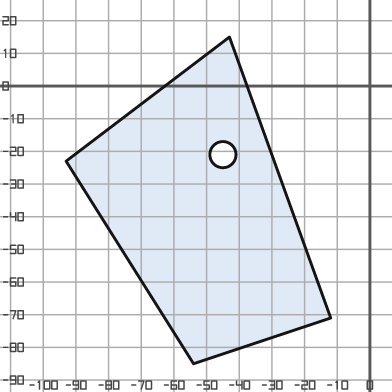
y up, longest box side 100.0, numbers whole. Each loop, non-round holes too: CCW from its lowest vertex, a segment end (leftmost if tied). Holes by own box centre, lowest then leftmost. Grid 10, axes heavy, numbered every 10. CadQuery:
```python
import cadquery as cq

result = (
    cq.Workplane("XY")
    .moveTo(-54.0, -85.0)
    .lineTo(-12.0, -71.0)
    .lineTo(-43.0, 15.0)
    .lineTo(-93.0, -23.0)
    .close()
    .moveTo(-45.0, -21.0)
    .circle(4.0)
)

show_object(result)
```